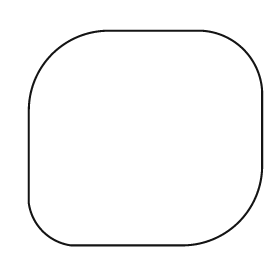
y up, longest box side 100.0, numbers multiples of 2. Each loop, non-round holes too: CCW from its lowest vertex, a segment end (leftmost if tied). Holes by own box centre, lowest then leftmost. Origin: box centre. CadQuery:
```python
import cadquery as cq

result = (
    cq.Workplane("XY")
    .moveTo(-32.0, -46.0)
    .lineTo(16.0, -46.0)
    .threePointArc((40.0, -36.0), (50.0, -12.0))
    .lineTo(50.0, 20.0)
    .threePointArc((42.0, 38.0), (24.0, 46.0))
    .lineTo(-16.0, 46.0)
    .threePointArc((-40.0, 36.0), (-50.0, 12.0))
    .lineTo(-50.0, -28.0)
    .threePointArc((-44.0, -40.0), (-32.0, -46.0))
    .close()
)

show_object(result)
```